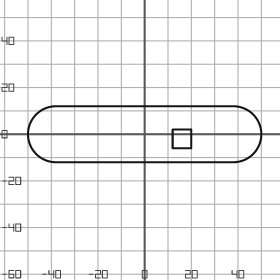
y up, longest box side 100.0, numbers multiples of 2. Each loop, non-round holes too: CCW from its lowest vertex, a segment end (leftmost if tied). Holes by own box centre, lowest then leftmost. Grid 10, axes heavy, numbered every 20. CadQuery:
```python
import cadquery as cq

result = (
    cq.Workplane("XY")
    .moveTo(-38.0, -12.0)
    .lineTo(38.0, -12.0)
    .threePointArc((50.0, 0.0), (38.0, 12.0))
    .lineTo(-38.0, 12.0)
    .threePointArc((-50.0, 0.0), (-38.0, -12.0))
    .close()
    .moveTo(12.0, -6.0)
    .lineTo(20.0, -6.0)
    .lineTo(20.0, 2.0)
    .lineTo(12.0, 2.0)
    .close()
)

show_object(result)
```